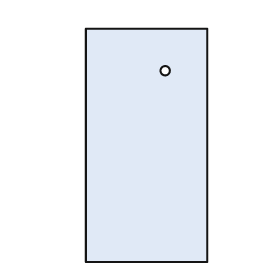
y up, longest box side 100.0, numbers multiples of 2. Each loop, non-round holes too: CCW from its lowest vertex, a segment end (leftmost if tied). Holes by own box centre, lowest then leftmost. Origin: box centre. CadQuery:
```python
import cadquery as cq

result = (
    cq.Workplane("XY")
    .moveTo(-26.0, -50.0)
    .lineTo(26.0, -50.0)
    .lineTo(26.0, 50.0)
    .lineTo(-26.0, 50.0)
    .close()
    .moveTo(8.0, 32.0)
    .circle(2.0)
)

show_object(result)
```